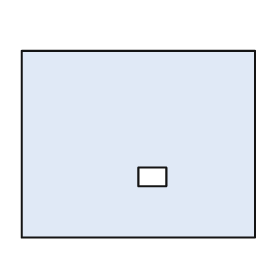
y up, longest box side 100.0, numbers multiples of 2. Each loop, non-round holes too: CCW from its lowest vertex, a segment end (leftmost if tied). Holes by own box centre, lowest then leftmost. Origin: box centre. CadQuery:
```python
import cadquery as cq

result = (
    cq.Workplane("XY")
    .moveTo(-50.0, -40.0)
    .lineTo(50.0, -40.0)
    .lineTo(50.0, 40.0)
    .lineTo(-50.0, 40.0)
    .close()
    .moveTo(0.0, -18.0)
    .lineTo(12.0, -18.0)
    .lineTo(12.0, -10.0)
    .lineTo(0.0, -10.0)
    .close()
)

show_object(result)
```